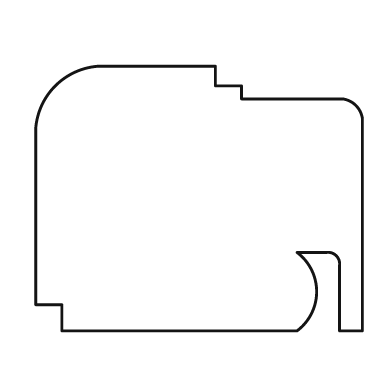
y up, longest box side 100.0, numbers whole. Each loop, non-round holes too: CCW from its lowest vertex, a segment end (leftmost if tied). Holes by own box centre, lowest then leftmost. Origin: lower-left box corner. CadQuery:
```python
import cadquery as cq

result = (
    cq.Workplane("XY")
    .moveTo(8.0, 0.0)
    .lineTo(80.0, 0.0)
    .threePointArc((86.0, 12.0), (80.0, 24.0))
    .lineTo(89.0, 24.0)
    .threePointArc((92.0, 23.0), (93.0, 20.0))
    .lineTo(93.0, 0.0)
    .lineTo(100.0, 0.0)
    .lineTo(100.0, 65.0)
    .threePointArc((98.0, 69.0), (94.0, 71.0))
    .lineTo(63.0, 71.0)
    .lineTo(63.0, 75.0)
    .lineTo(55.0, 75.0)
    .lineTo(55.0, 81.0)
    .lineTo(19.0, 81.0)
    .threePointArc((6.0, 75.0), (0.0, 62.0))
    .lineTo(0.0, 8.0)
    .lineTo(8.0, 8.0)
    .close()
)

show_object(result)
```